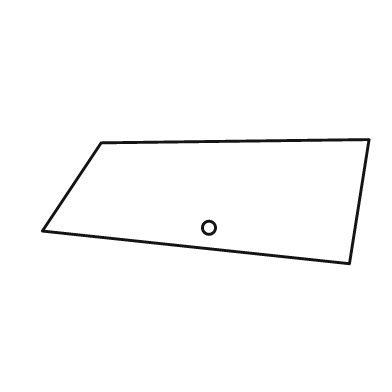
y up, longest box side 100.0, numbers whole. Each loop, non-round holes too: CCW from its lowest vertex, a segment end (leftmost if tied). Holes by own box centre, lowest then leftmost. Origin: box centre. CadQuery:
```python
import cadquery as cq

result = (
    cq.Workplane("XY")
    .moveTo(44.0, -19.0)
    .lineTo(50.0, 19.0)
    .lineTo(-32.0, 18.0)
    .lineTo(-50.0, -9.0)
    .close()
    .moveTo(1.0, -8.0)
    .circle(2.0)
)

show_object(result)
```